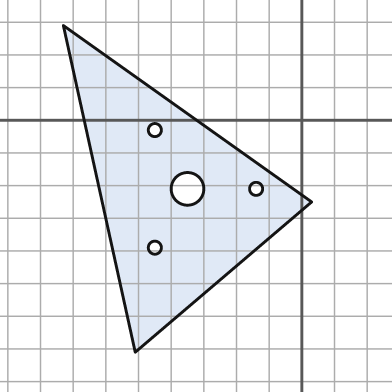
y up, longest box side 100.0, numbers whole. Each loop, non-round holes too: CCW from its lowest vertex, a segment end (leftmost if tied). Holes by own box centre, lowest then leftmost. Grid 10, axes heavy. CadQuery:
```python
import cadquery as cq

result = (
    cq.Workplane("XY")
    .moveTo(-51.0, -71.0)
    .lineTo(3.0, -25.0)
    .lineTo(-73.0, 29.0)
    .close()
    .moveTo(-45.0, -39.0)
    .circle(2.0)
    .moveTo(-35.0, -21.0)
    .circle(5.0)
    .moveTo(-14.0, -21.0)
    .circle(2.0)
    .moveTo(-45.0, -3.0)
    .circle(2.0)
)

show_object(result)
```